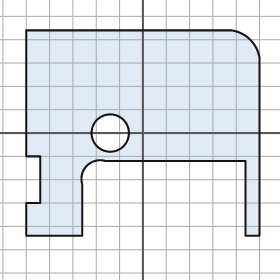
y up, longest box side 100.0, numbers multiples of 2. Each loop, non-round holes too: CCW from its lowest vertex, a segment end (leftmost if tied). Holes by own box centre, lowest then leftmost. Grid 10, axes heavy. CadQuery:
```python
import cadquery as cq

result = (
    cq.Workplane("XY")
    .moveTo(-50.0, -44.0)
    .lineTo(-26.0, -44.0)
    .lineTo(-26.0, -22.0)
    .threePointArc((-24.0, -14.0), (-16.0, -12.0))
    .lineTo(44.0, -12.0)
    .lineTo(44.0, -44.0)
    .lineTo(50.0, -44.0)
    .lineTo(50.0, 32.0)
    .threePointArc((46.0, 40.0), (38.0, 44.0))
    .lineTo(-50.0, 44.0)
    .lineTo(-50.0, -10.0)
    .lineTo(-44.0, -10.0)
    .lineTo(-44.0, -30.0)
    .lineTo(-50.0, -30.0)
    .close()
    .moveTo(-14.0, 0.0)
    .circle(8.0)
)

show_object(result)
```